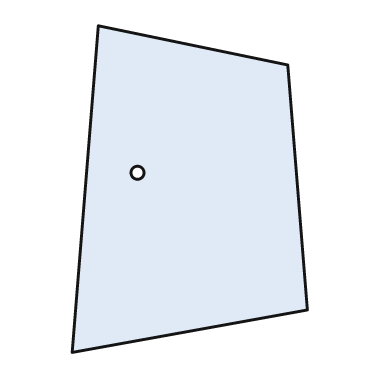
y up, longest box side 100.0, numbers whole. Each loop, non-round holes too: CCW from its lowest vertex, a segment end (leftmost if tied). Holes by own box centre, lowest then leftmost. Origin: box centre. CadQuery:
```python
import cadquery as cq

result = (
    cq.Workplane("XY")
    .moveTo(-36.0, -50.0)
    .lineTo(36.0, -37.0)
    .lineTo(30.0, 38.0)
    .lineTo(-28.0, 50.0)
    .close()
    .moveTo(-16.0, 5.0)
    .circle(2.0)
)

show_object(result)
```